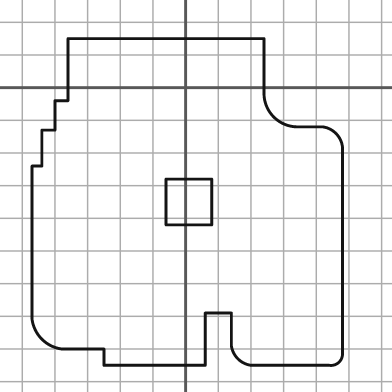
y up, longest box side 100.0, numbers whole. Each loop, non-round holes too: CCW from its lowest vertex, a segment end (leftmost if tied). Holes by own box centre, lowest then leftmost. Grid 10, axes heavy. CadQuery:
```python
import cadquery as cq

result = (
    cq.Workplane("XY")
    .moveTo(-25.0, -85.0)
    .lineTo(6.0, -85.0)
    .lineTo(6.0, -69.0)
    .lineTo(14.0, -69.0)
    .lineTo(14.0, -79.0)
    .threePointArc((16.0, -83.0), (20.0, -85.0))
    .lineTo(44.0, -85.0)
    .threePointArc((47.0, -84.0), (48.0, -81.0))
    .lineTo(48.0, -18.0)
    .threePointArc((46.0, -14.0), (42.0, -12.0))
    .lineTo(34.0, -12.0)
    .threePointArc((27.0, -9.0), (24.0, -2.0))
    .lineTo(24.0, 15.0)
    .lineTo(-36.0, 15.0)
    .lineTo(-36.0, -4.0)
    .lineTo(-40.0, -4.0)
    .lineTo(-40.0, -13.0)
    .lineTo(-44.0, -13.0)
    .lineTo(-44.0, -24.0)
    .lineTo(-47.0, -24.0)
    .lineTo(-47.0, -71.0)
    .threePointArc((-44.0, -77.0), (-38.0, -80.0))
    .lineTo(-25.0, -80.0)
    .close()
    .moveTo(-6.0, -42.0)
    .lineTo(8.0, -42.0)
    .lineTo(8.0, -28.0)
    .lineTo(-6.0, -28.0)
    .close()
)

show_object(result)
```